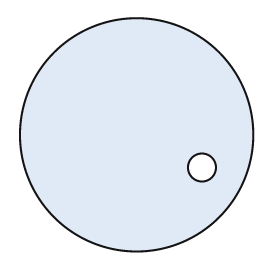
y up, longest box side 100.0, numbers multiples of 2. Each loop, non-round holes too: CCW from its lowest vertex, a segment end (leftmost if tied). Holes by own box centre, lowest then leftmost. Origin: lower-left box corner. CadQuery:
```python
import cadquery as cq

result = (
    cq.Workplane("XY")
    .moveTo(50.0, 50.0)
    .circle(50.0)
    .moveTo(78.0, 36.0)
    .circle(6.0)
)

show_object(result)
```